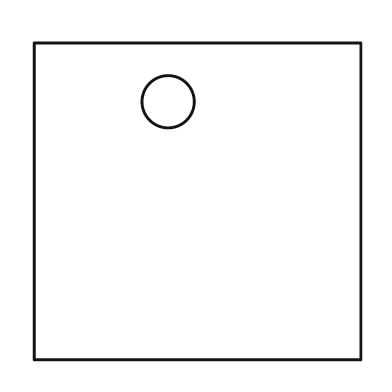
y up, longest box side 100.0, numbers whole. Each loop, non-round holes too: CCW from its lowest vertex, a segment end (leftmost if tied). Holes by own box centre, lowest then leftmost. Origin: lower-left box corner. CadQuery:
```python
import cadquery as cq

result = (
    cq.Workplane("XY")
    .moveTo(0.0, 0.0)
    .lineTo(100.0, 0.0)
    .lineTo(100.0, 97.0)
    .lineTo(0.0, 97.0)
    .close()
    .moveTo(41.0, 79.0)
    .circle(8.0)
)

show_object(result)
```